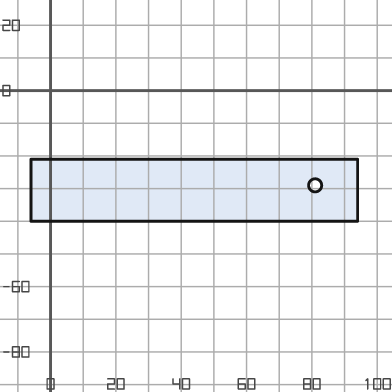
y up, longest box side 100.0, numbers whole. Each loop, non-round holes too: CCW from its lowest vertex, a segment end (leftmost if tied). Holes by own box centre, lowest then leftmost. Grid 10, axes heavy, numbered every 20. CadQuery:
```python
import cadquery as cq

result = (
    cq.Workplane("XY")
    .moveTo(-6.0, -40.0)
    .lineTo(94.0, -40.0)
    .lineTo(94.0, -21.0)
    .lineTo(-6.0, -21.0)
    .close()
    .moveTo(81.0, -29.0)
    .circle(2.0)
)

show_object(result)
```